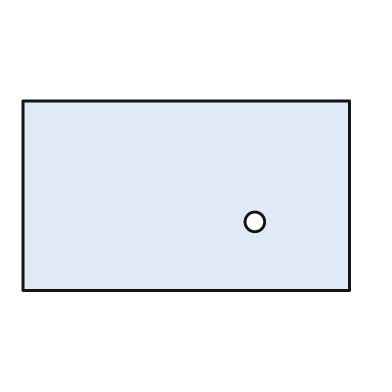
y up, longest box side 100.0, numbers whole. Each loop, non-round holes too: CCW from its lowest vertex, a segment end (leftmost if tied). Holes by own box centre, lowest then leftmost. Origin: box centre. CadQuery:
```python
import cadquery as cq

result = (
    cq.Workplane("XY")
    .moveTo(-50.0, -29.0)
    .lineTo(50.0, -29.0)
    .lineTo(50.0, 29.0)
    .lineTo(-50.0, 29.0)
    .close()
    .moveTo(21.0, -8.0)
    .circle(3.0)
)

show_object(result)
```